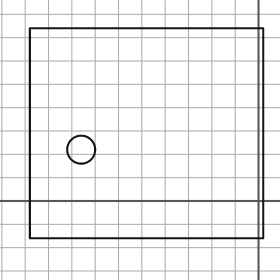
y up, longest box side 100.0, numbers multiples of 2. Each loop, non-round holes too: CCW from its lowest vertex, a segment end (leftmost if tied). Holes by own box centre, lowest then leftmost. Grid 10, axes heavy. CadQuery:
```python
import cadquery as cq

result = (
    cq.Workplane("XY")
    .moveTo(-98.0, -16.0)
    .lineTo(2.0, -16.0)
    .lineTo(2.0, 74.0)
    .lineTo(-98.0, 74.0)
    .close()
    .moveTo(-76.0, 22.0)
    .circle(6.0)
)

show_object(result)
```